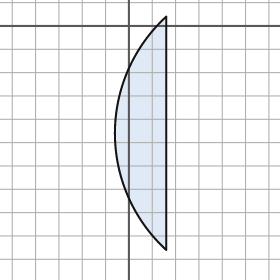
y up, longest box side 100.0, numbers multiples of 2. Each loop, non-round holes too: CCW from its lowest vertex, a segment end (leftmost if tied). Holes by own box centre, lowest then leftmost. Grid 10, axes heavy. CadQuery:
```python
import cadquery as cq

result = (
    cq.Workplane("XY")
    .moveTo(16.0, -96.0)
    .lineTo(16.0, 4.0)
    .threePointArc((-6.0, -46.0), (16.0, -96.0))
    .close()
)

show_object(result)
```